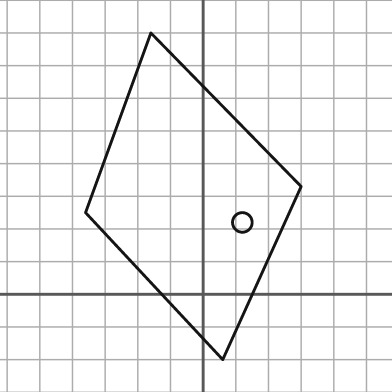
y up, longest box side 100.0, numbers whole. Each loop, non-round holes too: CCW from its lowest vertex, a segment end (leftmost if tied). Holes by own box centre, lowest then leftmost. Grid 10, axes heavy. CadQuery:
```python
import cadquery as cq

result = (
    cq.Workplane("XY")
    .moveTo(6.0, -20.0)
    .lineTo(30.0, 33.0)
    .lineTo(-16.0, 80.0)
    .lineTo(-36.0, 25.0)
    .close()
    .moveTo(12.0, 22.0)
    .circle(3.0)
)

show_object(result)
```